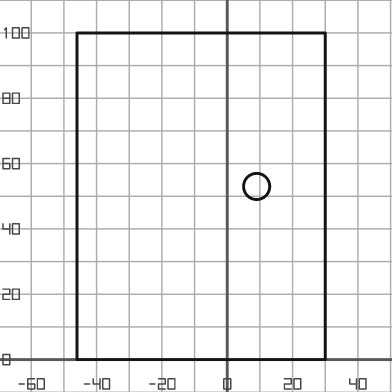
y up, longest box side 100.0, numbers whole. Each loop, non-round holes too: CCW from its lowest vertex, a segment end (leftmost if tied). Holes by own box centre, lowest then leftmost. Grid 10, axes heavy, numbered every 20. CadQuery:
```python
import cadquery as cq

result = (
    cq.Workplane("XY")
    .moveTo(-46.0, 0.0)
    .lineTo(30.0, 0.0)
    .lineTo(30.0, 100.0)
    .lineTo(-46.0, 100.0)
    .close()
    .moveTo(9.0, 53.0)
    .circle(4.0)
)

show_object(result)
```